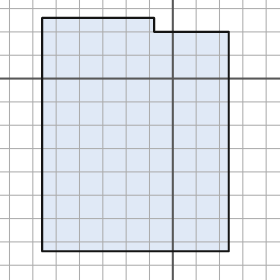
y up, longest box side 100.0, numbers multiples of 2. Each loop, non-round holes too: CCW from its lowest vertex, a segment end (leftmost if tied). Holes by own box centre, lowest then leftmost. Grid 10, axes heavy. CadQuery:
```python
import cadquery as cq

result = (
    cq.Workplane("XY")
    .moveTo(-56.0, -74.0)
    .lineTo(24.0, -74.0)
    .lineTo(24.0, 20.0)
    .lineTo(-8.0, 20.0)
    .lineTo(-8.0, 26.0)
    .lineTo(-56.0, 26.0)
    .close()
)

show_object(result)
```